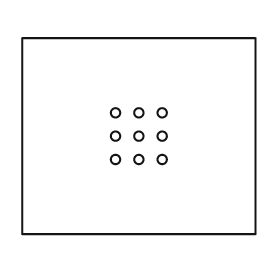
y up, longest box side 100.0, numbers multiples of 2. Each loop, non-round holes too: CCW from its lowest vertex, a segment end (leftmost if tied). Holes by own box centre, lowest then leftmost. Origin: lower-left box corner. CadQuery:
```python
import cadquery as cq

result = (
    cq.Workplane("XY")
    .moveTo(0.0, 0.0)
    .lineTo(100.0, 0.0)
    .lineTo(100.0, 84.0)
    .lineTo(0.0, 84.0)
    .close()
    .moveTo(40.0, 32.0)
    .circle(2.0)
    .moveTo(50.0, 32.0)
    .circle(2.0)
    .moveTo(60.0, 32.0)
    .circle(2.0)
    .moveTo(40.0, 42.0)
    .circle(2.0)
    .moveTo(50.0, 42.0)
    .circle(2.0)
    .moveTo(60.0, 42.0)
    .circle(2.0)
    .moveTo(40.0, 52.0)
    .circle(2.0)
    .moveTo(50.0, 52.0)
    .circle(2.0)
    .moveTo(60.0, 52.0)
    .circle(2.0)
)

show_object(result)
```